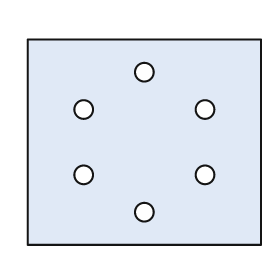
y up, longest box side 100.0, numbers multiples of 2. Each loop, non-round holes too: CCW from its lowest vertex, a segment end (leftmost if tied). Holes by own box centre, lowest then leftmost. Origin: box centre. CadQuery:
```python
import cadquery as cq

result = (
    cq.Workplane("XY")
    .moveTo(-50.0, -44.0)
    .lineTo(50.0, -44.0)
    .lineTo(50.0, 44.0)
    .lineTo(-50.0, 44.0)
    .close()
    .moveTo(0.0, -30.0)
    .circle(4.0)
    .moveTo(-26.0, -14.0)
    .circle(4.0)
    .moveTo(26.0, -14.0)
    .circle(4.0)
    .moveTo(-26.0, 14.0)
    .circle(4.0)
    .moveTo(26.0, 14.0)
    .circle(4.0)
    .moveTo(0.0, 30.0)
    .circle(4.0)
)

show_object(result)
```